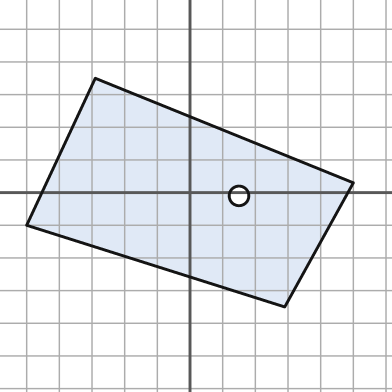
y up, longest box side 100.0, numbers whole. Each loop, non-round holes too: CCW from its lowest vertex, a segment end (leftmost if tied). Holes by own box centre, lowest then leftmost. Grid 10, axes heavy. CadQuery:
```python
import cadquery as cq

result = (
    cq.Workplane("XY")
    .moveTo(29.0, -35.0)
    .lineTo(50.0, 3.0)
    .lineTo(-29.0, 35.0)
    .lineTo(-50.0, -10.0)
    .close()
    .moveTo(15.0, -1.0)
    .circle(3.0)
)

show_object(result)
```